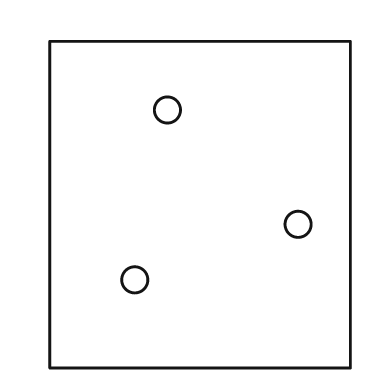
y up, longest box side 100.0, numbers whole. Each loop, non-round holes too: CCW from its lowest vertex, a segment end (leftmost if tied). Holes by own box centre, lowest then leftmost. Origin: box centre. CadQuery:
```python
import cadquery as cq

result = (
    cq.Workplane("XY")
    .moveTo(-46.0, -50.0)
    .lineTo(46.0, -50.0)
    .lineTo(46.0, 50.0)
    .lineTo(-46.0, 50.0)
    .close()
    .moveTo(-20.0, -23.0)
    .circle(4.0)
    .moveTo(30.0, -6.0)
    .circle(4.0)
    .moveTo(-10.0, 29.0)
    .circle(4.0)
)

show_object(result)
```